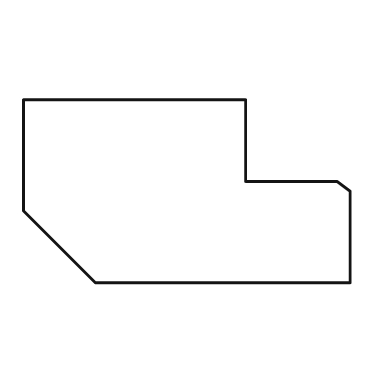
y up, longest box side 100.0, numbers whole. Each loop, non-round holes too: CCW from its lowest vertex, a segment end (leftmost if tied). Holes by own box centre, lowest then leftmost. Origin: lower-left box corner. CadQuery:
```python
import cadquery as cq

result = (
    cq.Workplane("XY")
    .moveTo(22.0, 0.0)
    .lineTo(100.0, 0.0)
    .lineTo(100.0, 28.0)
    .lineTo(96.0, 31.0)
    .lineTo(68.0, 31.0)
    .lineTo(68.0, 56.0)
    .lineTo(0.0, 56.0)
    .lineTo(0.0, 22.0)
    .close()
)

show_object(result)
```